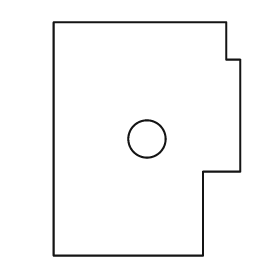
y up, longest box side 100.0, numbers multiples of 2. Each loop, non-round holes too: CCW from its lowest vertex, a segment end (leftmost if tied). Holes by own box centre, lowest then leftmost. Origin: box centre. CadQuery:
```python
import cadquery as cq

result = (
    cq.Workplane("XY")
    .moveTo(-40.0, -50.0)
    .lineTo(24.0, -50.0)
    .lineTo(24.0, -14.0)
    .lineTo(40.0, -14.0)
    .lineTo(40.0, 34.0)
    .lineTo(34.0, 34.0)
    .lineTo(34.0, 50.0)
    .lineTo(-40.0, 50.0)
    .close()
    .moveTo(0.0, 0.0)
    .circle(8.0)
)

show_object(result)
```